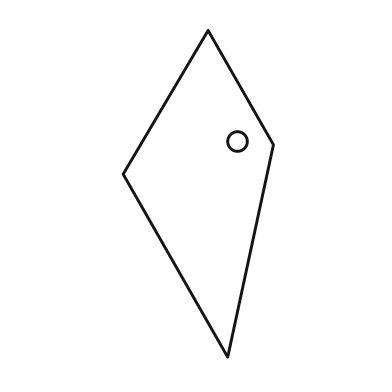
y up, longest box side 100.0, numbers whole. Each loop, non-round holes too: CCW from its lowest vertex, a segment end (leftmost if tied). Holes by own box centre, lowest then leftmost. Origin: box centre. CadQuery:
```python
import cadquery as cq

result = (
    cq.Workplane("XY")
    .moveTo(9.0, -50.0)
    .lineTo(23.0, 15.0)
    .lineTo(3.0, 50.0)
    .lineTo(-23.0, 6.0)
    .close()
    .moveTo(12.0, 16.0)
    .circle(3.0)
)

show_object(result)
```